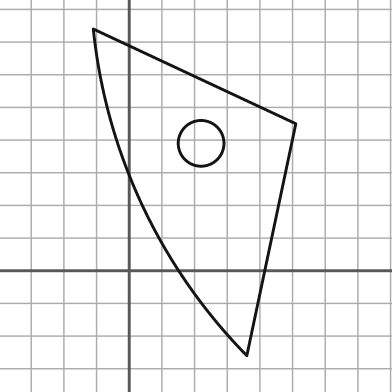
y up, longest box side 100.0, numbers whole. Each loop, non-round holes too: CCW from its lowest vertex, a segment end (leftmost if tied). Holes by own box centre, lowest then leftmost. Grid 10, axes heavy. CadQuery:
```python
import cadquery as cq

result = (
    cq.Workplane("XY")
    .moveTo(36.0, -26.0)
    .lineTo(51.0, 45.0)
    .lineTo(-11.0, 74.0)
    .threePointArc((4.0, 20.0), (36.0, -26.0))
    .close()
    .moveTo(22.0, 39.0)
    .circle(7.0)
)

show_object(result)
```